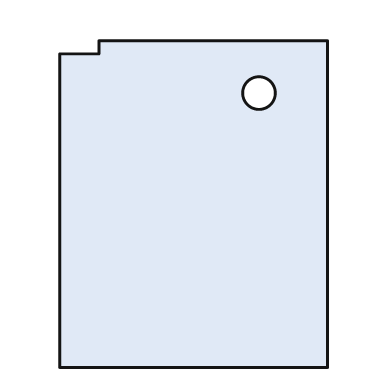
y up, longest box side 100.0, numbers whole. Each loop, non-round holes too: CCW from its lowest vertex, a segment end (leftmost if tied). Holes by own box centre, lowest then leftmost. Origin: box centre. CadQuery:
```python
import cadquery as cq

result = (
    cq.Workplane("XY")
    .moveTo(-41.0, -50.0)
    .lineTo(41.0, -50.0)
    .lineTo(41.0, 50.0)
    .lineTo(-29.0, 50.0)
    .lineTo(-29.0, 46.0)
    .lineTo(-41.0, 46.0)
    .close()
    .moveTo(20.0, 34.0)
    .circle(5.0)
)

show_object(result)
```